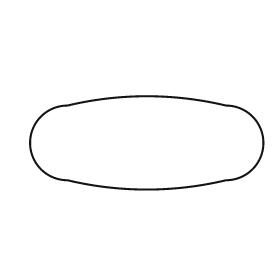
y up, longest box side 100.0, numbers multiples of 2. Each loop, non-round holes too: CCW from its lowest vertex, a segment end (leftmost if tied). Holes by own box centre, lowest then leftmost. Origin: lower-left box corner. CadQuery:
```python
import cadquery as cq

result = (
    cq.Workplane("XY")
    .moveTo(16.0, 4.0)
    .threePointArc((50.0, 0.0), (84.0, 4.0))
    .threePointArc((100.0, 20.0), (84.0, 36.0))
    .threePointArc((50.0, 40.0), (16.0, 36.0))
    .threePointArc((0.0, 20.0), (16.0, 4.0))
    .close()
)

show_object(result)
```